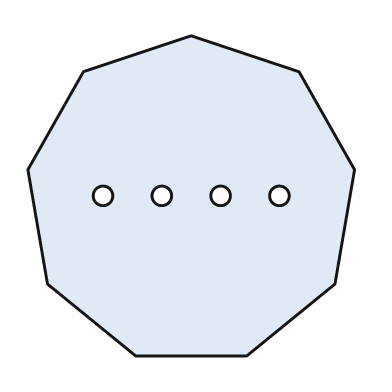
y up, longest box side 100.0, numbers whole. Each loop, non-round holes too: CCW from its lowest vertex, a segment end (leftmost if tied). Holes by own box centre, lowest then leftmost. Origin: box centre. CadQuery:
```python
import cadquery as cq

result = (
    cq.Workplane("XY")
    .moveTo(-17.0, -49.0)
    .lineTo(17.0, -49.0)
    .lineTo(44.0, -27.0)
    .lineTo(50.0, 8.0)
    .lineTo(33.0, 38.0)
    .lineTo(0.0, 49.0)
    .lineTo(-33.0, 38.0)
    .lineTo(-50.0, 8.0)
    .lineTo(-44.0, -27.0)
    .close()
    .moveTo(-27.0, 0.0)
    .circle(3.0)
    .moveTo(-9.0, 0.0)
    .circle(3.0)
    .moveTo(9.0, 0.0)
    .circle(3.0)
    .moveTo(27.0, 0.0)
    .circle(3.0)
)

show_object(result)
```